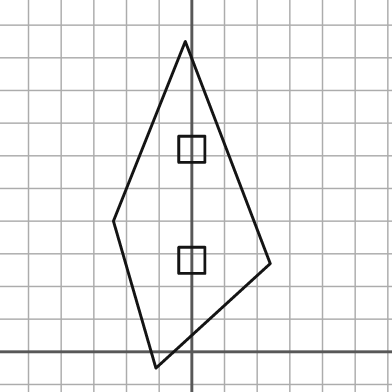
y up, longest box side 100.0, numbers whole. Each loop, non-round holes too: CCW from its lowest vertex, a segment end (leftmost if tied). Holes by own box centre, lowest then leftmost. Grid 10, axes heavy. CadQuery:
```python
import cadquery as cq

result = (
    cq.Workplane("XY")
    .moveTo(-11.0, -5.0)
    .lineTo(24.0, 27.0)
    .lineTo(-2.0, 95.0)
    .lineTo(-24.0, 40.0)
    .close()
    .moveTo(-4.0, 24.0)
    .lineTo(4.0, 24.0)
    .lineTo(4.0, 32.0)
    .lineTo(-4.0, 32.0)
    .close()
    .moveTo(-4.0, 58.0)
    .lineTo(4.0, 58.0)
    .lineTo(4.0, 66.0)
    .lineTo(-4.0, 66.0)
    .close()
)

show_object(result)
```